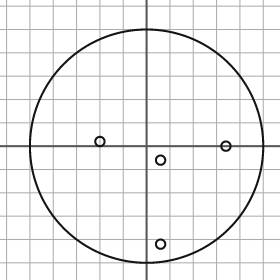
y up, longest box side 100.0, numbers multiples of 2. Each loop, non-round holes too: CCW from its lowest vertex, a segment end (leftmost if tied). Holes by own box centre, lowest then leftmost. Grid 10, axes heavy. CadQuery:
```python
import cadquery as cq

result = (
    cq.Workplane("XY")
    .moveTo(0.0, 0.0)
    .circle(50.0)
    .moveTo(6.0, -42.0)
    .circle(2.0)
    .moveTo(6.0, -6.0)
    .circle(2.0)
    .moveTo(34.0, 0.0)
    .circle(2.0)
    .moveTo(-20.0, 2.0)
    .circle(2.0)
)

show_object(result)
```